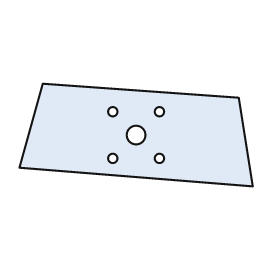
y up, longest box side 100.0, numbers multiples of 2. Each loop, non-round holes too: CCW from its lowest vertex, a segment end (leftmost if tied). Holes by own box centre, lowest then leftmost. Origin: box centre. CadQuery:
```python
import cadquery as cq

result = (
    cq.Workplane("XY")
    .moveTo(50.0, -22.0)
    .lineTo(44.0, 16.0)
    .lineTo(-40.0, 22.0)
    .lineTo(-50.0, -14.0)
    .close()
    .moveTo(-10.0, -10.0)
    .circle(2.0)
    .moveTo(10.0, -10.0)
    .circle(2.0)
    .moveTo(0.0, 0.0)
    .circle(4.0)
    .moveTo(-10.0, 10.0)
    .circle(2.0)
    .moveTo(10.0, 10.0)
    .circle(2.0)
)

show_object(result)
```